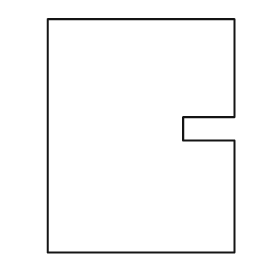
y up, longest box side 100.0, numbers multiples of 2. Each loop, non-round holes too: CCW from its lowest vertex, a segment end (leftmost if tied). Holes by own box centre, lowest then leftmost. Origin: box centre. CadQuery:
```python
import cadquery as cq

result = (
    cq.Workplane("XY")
    .moveTo(-40.0, -50.0)
    .lineTo(40.0, -50.0)
    .lineTo(40.0, -2.0)
    .lineTo(18.0, -2.0)
    .lineTo(18.0, 8.0)
    .lineTo(40.0, 8.0)
    .lineTo(40.0, 50.0)
    .lineTo(-40.0, 50.0)
    .close()
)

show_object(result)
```